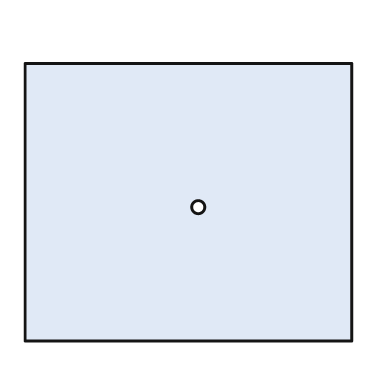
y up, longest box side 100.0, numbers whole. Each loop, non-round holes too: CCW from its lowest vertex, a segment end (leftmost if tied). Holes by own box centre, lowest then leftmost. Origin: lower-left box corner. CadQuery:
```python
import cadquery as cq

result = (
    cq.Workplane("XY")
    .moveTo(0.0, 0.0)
    .lineTo(100.0, 0.0)
    .lineTo(100.0, 85.0)
    .lineTo(0.0, 85.0)
    .close()
    .moveTo(53.0, 41.0)
    .circle(2.0)
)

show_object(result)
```